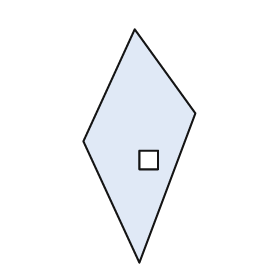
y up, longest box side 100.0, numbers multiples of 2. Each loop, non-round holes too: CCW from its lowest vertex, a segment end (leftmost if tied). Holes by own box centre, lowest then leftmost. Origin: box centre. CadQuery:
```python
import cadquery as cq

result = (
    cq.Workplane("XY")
    .moveTo(0.0, -50.0)
    .lineTo(24.0, 14.0)
    .lineTo(-2.0, 50.0)
    .lineTo(-24.0, 2.0)
    .close()
    .moveTo(0.0, -10.0)
    .lineTo(8.0, -10.0)
    .lineTo(8.0, -2.0)
    .lineTo(0.0, -2.0)
    .close()
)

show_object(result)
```